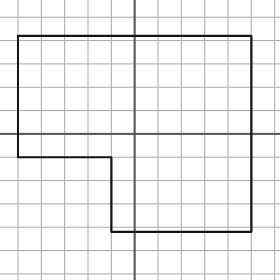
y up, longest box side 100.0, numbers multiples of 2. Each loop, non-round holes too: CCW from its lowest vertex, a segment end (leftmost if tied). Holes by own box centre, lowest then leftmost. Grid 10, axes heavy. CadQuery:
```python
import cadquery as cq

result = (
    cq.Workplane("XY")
    .moveTo(-10.0, -42.0)
    .lineTo(50.0, -42.0)
    .lineTo(50.0, 42.0)
    .lineTo(-50.0, 42.0)
    .lineTo(-50.0, -10.0)
    .lineTo(-10.0, -10.0)
    .close()
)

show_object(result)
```